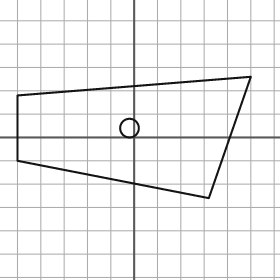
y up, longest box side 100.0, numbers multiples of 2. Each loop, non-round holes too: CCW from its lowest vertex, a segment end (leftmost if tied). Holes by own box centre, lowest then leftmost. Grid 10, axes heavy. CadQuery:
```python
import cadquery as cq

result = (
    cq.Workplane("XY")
    .moveTo(32.0, -26.0)
    .lineTo(50.0, 26.0)
    .lineTo(-50.0, 18.0)
    .lineTo(-50.0, -10.0)
    .close()
    .moveTo(-2.0, 4.0)
    .circle(4.0)
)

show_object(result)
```